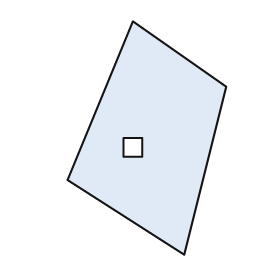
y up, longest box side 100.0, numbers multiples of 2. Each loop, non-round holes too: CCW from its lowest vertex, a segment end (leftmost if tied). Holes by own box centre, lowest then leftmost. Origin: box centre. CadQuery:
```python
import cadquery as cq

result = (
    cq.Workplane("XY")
    .moveTo(16.0, -50.0)
    .lineTo(34.0, 22.0)
    .lineTo(-6.0, 50.0)
    .lineTo(-34.0, -18.0)
    .close()
    .moveTo(-10.0, -8.0)
    .lineTo(-2.0, -8.0)
    .lineTo(-2.0, 0.0)
    .lineTo(-10.0, 0.0)
    .close()
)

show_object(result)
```